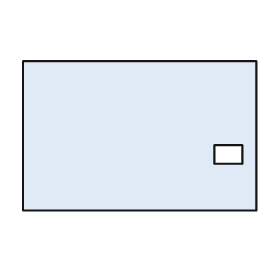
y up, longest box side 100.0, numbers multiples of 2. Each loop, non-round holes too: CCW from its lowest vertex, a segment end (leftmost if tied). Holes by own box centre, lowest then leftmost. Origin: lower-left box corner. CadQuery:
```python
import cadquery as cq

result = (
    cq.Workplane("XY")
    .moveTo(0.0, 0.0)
    .lineTo(100.0, 0.0)
    .lineTo(100.0, 64.0)
    .lineTo(0.0, 64.0)
    .close()
    .moveTo(82.0, 20.0)
    .lineTo(94.0, 20.0)
    .lineTo(94.0, 28.0)
    .lineTo(82.0, 28.0)
    .close()
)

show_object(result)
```